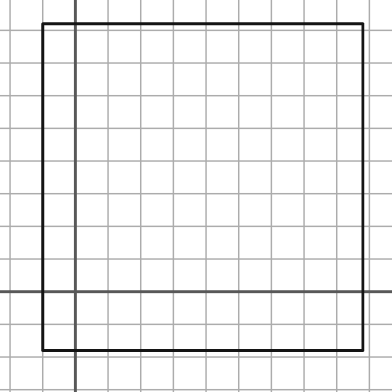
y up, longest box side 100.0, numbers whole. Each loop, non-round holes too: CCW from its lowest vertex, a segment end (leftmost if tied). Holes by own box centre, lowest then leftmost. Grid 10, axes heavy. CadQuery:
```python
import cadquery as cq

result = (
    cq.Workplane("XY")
    .moveTo(-10.0, -18.0)
    .lineTo(88.0, -18.0)
    .lineTo(88.0, 82.0)
    .lineTo(-10.0, 82.0)
    .close()
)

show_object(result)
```